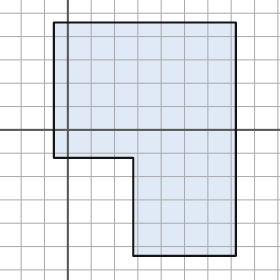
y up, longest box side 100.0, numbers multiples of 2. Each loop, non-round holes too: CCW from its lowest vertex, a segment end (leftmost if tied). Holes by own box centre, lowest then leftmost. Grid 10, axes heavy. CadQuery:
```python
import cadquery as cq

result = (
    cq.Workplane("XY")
    .moveTo(28.0, -54.0)
    .lineTo(72.0, -54.0)
    .lineTo(72.0, 46.0)
    .lineTo(-6.0, 46.0)
    .lineTo(-6.0, -12.0)
    .lineTo(28.0, -12.0)
    .close()
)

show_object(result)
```